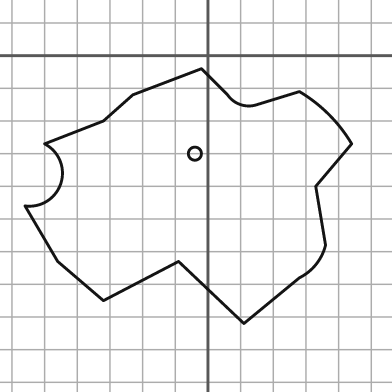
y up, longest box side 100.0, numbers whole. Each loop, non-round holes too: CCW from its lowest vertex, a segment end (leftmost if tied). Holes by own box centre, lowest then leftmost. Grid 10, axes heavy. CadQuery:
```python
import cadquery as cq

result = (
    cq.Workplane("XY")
    .moveTo(11.0, -82.0)
    .lineTo(28.0, -68.0)
    .threePointArc((33.0, -64.0), (36.0, -58.0))
    .lineTo(33.0, -40.0)
    .lineTo(44.0, -27.0)
    .threePointArc((37.0, -18.0), (28.0, -11.0))
    .lineTo(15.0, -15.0)
    .threePointArc((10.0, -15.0), (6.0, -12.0))
    .lineTo(-2.0, -4.0)
    .lineTo(-23.0, -12.0)
    .lineTo(-32.0, -20.0)
    .lineTo(-50.0, -27.0)
    .threePointArc((-45.0, -39.0), (-56.0, -46.0))
    .lineTo(-46.0, -63.0)
    .lineTo(-32.0, -75.0)
    .lineTo(-9.0, -63.0)
    .close()
    .moveTo(-4.0, -30.0)
    .circle(2.0)
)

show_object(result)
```